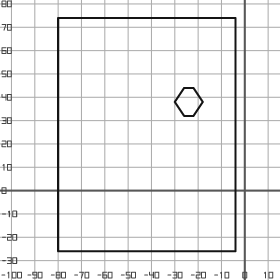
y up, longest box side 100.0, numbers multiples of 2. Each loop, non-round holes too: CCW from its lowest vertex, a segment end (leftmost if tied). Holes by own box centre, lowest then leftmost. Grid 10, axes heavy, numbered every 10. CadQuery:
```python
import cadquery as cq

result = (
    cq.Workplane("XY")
    .moveTo(-80.0, -26.0)
    .lineTo(-4.0, -26.0)
    .lineTo(-4.0, 74.0)
    .lineTo(-80.0, 74.0)
    .close()
    .moveTo(-26.0, 32.0)
    .lineTo(-22.0, 32.0)
    .lineTo(-18.0, 38.0)
    .lineTo(-22.0, 44.0)
    .lineTo(-26.0, 44.0)
    .lineTo(-30.0, 38.0)
    .close()
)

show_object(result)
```